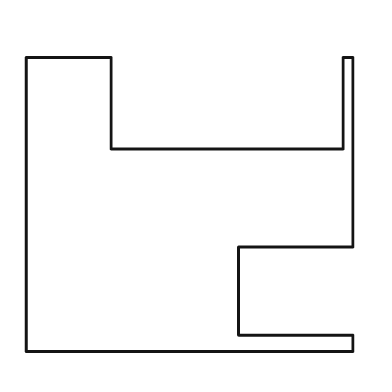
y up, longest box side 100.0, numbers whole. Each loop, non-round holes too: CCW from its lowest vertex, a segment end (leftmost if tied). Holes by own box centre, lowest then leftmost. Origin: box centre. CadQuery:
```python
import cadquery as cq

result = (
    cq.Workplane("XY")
    .moveTo(-50.0, -45.0)
    .lineTo(50.0, -45.0)
    .lineTo(50.0, -40.0)
    .lineTo(15.0, -40.0)
    .lineTo(15.0, -13.0)
    .lineTo(50.0, -13.0)
    .lineTo(50.0, 45.0)
    .lineTo(47.0, 45.0)
    .lineTo(47.0, 17.0)
    .lineTo(-24.0, 17.0)
    .lineTo(-24.0, 45.0)
    .lineTo(-50.0, 45.0)
    .close()
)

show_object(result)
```